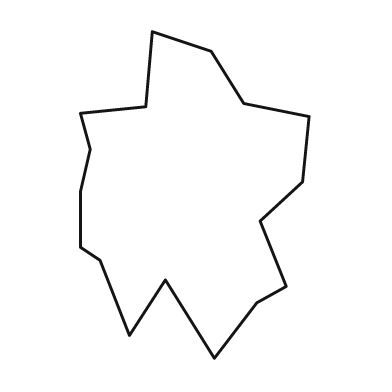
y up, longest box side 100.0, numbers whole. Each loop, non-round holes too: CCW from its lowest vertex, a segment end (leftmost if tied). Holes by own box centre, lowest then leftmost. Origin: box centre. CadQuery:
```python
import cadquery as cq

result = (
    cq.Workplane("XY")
    .moveTo(6.0, -50.0)
    .lineTo(19.0, -33.0)
    .lineTo(28.0, -28.0)
    .lineTo(20.0, -8.0)
    .lineTo(33.0, 4.0)
    .lineTo(35.0, 24.0)
    .lineTo(15.0, 28.0)
    .lineTo(5.0, 44.0)
    .lineTo(-13.0, 50.0)
    .lineTo(-15.0, 27.0)
    .lineTo(-35.0, 25.0)
    .lineTo(-32.0, 14.0)
    .lineTo(-35.0, 1.0)
    .lineTo(-35.0, -16.0)
    .lineTo(-29.0, -20.0)
    .lineTo(-20.0, -43.0)
    .lineTo(-9.0, -26.0)
    .close()
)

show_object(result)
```